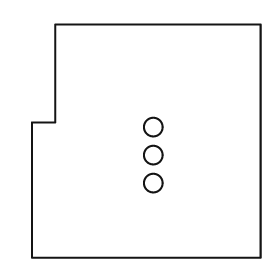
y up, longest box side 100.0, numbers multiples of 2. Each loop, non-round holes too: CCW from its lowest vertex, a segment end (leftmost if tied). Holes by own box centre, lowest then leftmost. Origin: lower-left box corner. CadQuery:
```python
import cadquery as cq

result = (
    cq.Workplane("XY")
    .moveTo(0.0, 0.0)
    .lineTo(98.0, 0.0)
    .lineTo(98.0, 100.0)
    .lineTo(10.0, 100.0)
    .lineTo(10.0, 58.0)
    .lineTo(0.0, 58.0)
    .close()
    .moveTo(52.0, 32.0)
    .circle(4.0)
    .moveTo(52.0, 44.0)
    .circle(4.0)
    .moveTo(52.0, 56.0)
    .circle(4.0)
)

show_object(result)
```